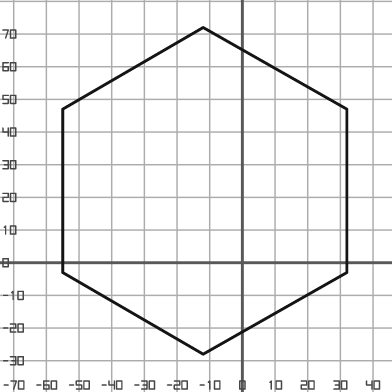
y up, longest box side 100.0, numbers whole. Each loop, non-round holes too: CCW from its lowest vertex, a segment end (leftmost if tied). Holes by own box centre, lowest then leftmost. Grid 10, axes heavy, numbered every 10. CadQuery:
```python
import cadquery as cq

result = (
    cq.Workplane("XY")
    .moveTo(-12.0, -28.0)
    .lineTo(32.0, -3.0)
    .lineTo(32.0, 47.0)
    .lineTo(-12.0, 72.0)
    .lineTo(-55.0, 47.0)
    .lineTo(-55.0, -3.0)
    .close()
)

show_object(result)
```